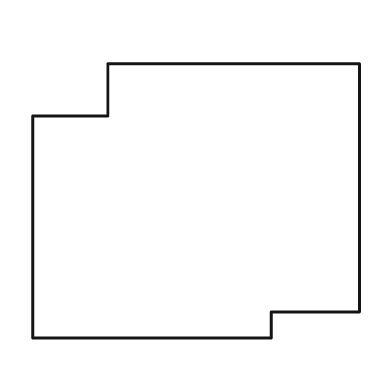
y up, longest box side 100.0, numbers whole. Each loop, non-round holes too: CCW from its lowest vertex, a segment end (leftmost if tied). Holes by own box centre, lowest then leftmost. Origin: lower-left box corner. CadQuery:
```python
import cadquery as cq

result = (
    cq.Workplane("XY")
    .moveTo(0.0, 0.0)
    .lineTo(73.0, 0.0)
    .lineTo(73.0, 8.0)
    .lineTo(100.0, 8.0)
    .lineTo(100.0, 84.0)
    .lineTo(23.0, 84.0)
    .lineTo(23.0, 68.0)
    .lineTo(0.0, 68.0)
    .close()
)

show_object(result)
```